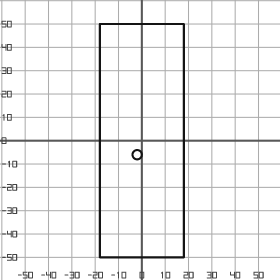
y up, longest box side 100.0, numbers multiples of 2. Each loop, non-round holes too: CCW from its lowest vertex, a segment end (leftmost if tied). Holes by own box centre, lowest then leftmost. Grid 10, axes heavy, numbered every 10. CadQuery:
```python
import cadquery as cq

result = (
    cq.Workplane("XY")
    .moveTo(-18.0, -50.0)
    .lineTo(18.0, -50.0)
    .lineTo(18.0, 50.0)
    .lineTo(-18.0, 50.0)
    .close()
    .moveTo(-2.0, -6.0)
    .circle(2.0)
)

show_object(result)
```